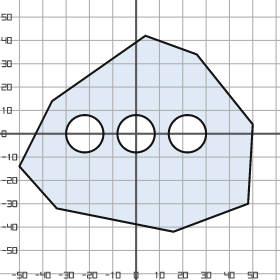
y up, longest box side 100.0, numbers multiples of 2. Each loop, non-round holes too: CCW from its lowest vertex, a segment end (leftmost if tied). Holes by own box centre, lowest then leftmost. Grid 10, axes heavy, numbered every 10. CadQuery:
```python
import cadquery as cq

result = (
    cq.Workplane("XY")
    .moveTo(16.0, -42.0)
    .lineTo(48.0, -30.0)
    .lineTo(50.0, 4.0)
    .lineTo(26.0, 34.0)
    .lineTo(4.0, 42.0)
    .lineTo(-36.0, 14.0)
    .lineTo(-50.0, -14.0)
    .lineTo(-34.0, -32.0)
    .close()
    .moveTo(-22.0, 0.0)
    .circle(8.0)
    .moveTo(0.0, 0.0)
    .circle(8.0)
    .moveTo(22.0, 0.0)
    .circle(8.0)
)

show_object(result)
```